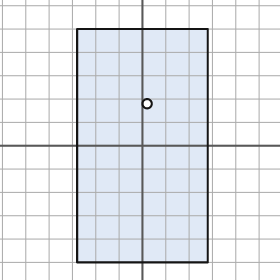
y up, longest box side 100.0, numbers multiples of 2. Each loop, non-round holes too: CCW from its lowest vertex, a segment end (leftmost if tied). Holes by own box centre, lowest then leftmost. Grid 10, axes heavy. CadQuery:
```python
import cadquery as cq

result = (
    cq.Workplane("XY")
    .moveTo(-28.0, -50.0)
    .lineTo(28.0, -50.0)
    .lineTo(28.0, 50.0)
    .lineTo(-28.0, 50.0)
    .close()
    .moveTo(2.0, 18.0)
    .circle(2.0)
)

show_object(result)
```